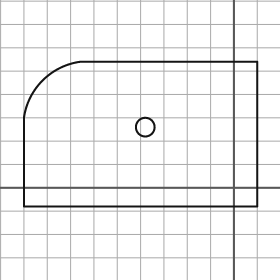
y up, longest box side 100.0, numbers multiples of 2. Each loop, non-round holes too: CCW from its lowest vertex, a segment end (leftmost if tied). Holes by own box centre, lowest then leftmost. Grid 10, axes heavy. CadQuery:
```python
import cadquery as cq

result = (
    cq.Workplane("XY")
    .moveTo(-90.0, -8.0)
    .lineTo(10.0, -8.0)
    .lineTo(10.0, 54.0)
    .lineTo(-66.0, 54.0)
    .threePointArc((-82.0, 46.0), (-90.0, 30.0))
    .close()
    .moveTo(-38.0, 26.0)
    .circle(4.0)
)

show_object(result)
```